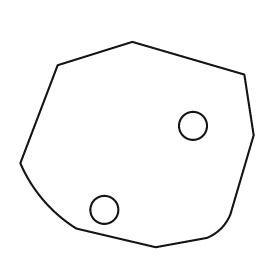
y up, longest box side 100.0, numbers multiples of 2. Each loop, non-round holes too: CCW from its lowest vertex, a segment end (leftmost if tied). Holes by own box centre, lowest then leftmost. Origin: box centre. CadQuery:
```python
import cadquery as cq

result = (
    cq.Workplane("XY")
    .moveTo(8.0, -44.0)
    .lineTo(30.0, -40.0)
    .threePointArc((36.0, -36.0), (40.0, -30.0))
    .lineTo(50.0, 4.0)
    .lineTo(46.0, 30.0)
    .lineTo(-2.0, 44.0)
    .lineTo(-34.0, 34.0)
    .lineTo(-50.0, -8.0)
    .threePointArc((-40.0, -24.0), (-26.0, -36.0))
    .close()
    .moveTo(-14.0, -28.0)
    .circle(6.0)
    .moveTo(24.0, 8.0)
    .circle(6.0)
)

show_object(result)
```